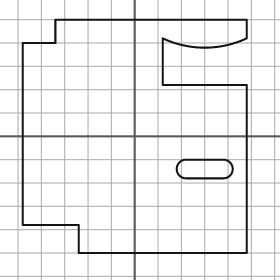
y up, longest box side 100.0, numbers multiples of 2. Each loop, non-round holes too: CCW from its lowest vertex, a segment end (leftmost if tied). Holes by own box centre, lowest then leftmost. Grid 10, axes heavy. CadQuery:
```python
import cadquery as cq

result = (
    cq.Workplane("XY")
    .moveTo(-24.0, -50.0)
    .lineTo(48.0, -50.0)
    .lineTo(48.0, 22.0)
    .lineTo(12.0, 22.0)
    .lineTo(12.0, 42.0)
    .threePointArc((30.0, 38.0), (48.0, 42.0))
    .lineTo(48.0, 50.0)
    .lineTo(-34.0, 50.0)
    .lineTo(-34.0, 40.0)
    .lineTo(-48.0, 40.0)
    .lineTo(-48.0, -38.0)
    .lineTo(-24.0, -38.0)
    .close()
    .moveTo(22.0, -18.0)
    .lineTo(38.0, -18.0)
    .threePointArc((42.0, -14.0), (38.0, -10.0))
    .lineTo(22.0, -10.0)
    .threePointArc((18.0, -14.0), (22.0, -18.0))
    .close()
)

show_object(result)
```